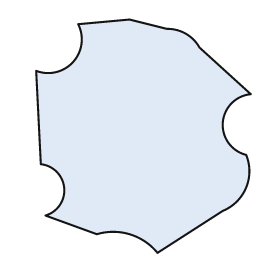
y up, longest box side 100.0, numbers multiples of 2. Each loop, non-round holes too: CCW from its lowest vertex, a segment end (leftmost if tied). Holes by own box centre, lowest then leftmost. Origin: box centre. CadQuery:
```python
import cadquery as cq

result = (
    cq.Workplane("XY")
    .moveTo(6.0, -50.0)
    .lineTo(34.0, -32.0)
    .threePointArc((44.0, -22.0), (44.0, -8.0))
    .threePointArc((34.0, 6.0), (46.0, 18.0))
    .lineTo(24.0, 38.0)
    .threePointArc((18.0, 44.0), (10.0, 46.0))
    .lineTo(-6.0, 50.0)
    .lineTo(-28.0, 48.0)
    .threePointArc((-30.0, 32.0), (-46.0, 28.0))
    .lineTo(-44.0, -12.0)
    .threePointArc((-34.0, -22.0), (-42.0, -34.0))
    .lineTo(-20.0, -42.0)
    .threePointArc((-6.0, -42.0), (6.0, -50.0))
    .close()
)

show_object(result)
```